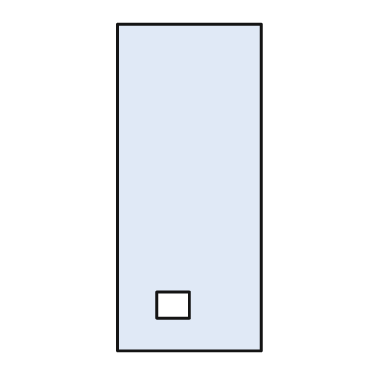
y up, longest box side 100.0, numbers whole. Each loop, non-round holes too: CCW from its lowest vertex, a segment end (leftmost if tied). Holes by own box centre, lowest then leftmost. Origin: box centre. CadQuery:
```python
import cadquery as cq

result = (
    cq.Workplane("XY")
    .moveTo(-22.0, -50.0)
    .lineTo(22.0, -50.0)
    .lineTo(22.0, 50.0)
    .lineTo(-22.0, 50.0)
    .close()
    .moveTo(-10.0, -40.0)
    .lineTo(0.0, -40.0)
    .lineTo(0.0, -32.0)
    .lineTo(-10.0, -32.0)
    .close()
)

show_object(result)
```